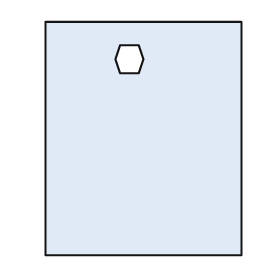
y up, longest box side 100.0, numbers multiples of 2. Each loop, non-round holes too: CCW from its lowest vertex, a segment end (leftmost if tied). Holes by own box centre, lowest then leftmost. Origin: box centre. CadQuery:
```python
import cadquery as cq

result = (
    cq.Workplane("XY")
    .moveTo(-42.0, -50.0)
    .lineTo(42.0, -50.0)
    .lineTo(42.0, 50.0)
    .lineTo(-42.0, 50.0)
    .close()
    .moveTo(-10.0, 28.0)
    .lineTo(-2.0, 28.0)
    .lineTo(0.0, 34.0)
    .lineTo(-2.0, 40.0)
    .lineTo(-10.0, 40.0)
    .lineTo(-12.0, 34.0)
    .close()
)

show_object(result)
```